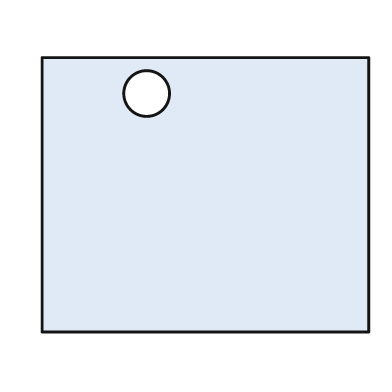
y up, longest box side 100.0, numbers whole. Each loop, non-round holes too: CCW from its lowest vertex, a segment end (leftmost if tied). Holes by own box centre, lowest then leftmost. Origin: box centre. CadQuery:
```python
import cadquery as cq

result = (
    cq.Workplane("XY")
    .moveTo(-50.0, -42.0)
    .lineTo(50.0, -42.0)
    .lineTo(50.0, 42.0)
    .lineTo(-50.0, 42.0)
    .close()
    .moveTo(-18.0, 31.0)
    .circle(7.0)
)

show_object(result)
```